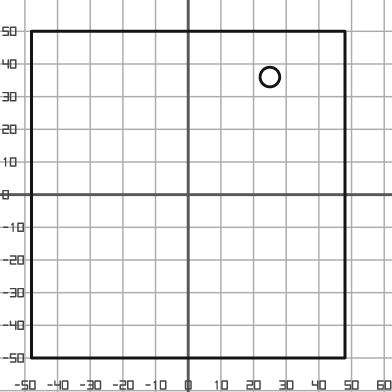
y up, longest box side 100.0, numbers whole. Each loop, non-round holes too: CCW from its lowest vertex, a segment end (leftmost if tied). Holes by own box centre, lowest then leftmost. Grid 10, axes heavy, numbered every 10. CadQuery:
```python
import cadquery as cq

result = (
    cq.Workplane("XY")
    .moveTo(-48.0, -50.0)
    .lineTo(48.0, -50.0)
    .lineTo(48.0, 50.0)
    .lineTo(-48.0, 50.0)
    .close()
    .moveTo(25.0, 36.0)
    .circle(3.0)
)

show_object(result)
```